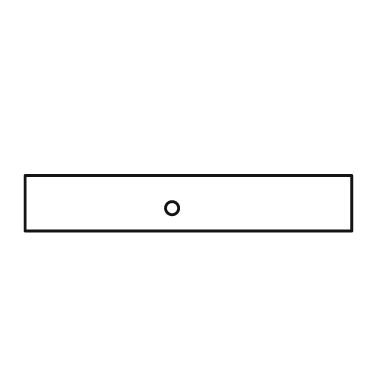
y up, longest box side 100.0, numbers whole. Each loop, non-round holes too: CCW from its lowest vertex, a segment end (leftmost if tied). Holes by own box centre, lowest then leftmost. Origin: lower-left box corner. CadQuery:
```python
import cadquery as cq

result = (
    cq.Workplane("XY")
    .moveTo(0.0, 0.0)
    .lineTo(100.0, 0.0)
    .lineTo(100.0, 17.0)
    .lineTo(0.0, 17.0)
    .close()
    .moveTo(45.0, 7.0)
    .circle(2.0)
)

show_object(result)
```